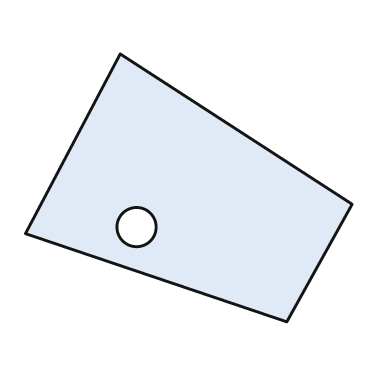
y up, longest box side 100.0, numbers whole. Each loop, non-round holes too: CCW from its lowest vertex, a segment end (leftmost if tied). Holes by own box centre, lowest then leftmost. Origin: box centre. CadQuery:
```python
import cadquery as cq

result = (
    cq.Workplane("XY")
    .moveTo(30.0, -41.0)
    .lineTo(50.0, -5.0)
    .lineTo(-21.0, 41.0)
    .lineTo(-50.0, -14.0)
    .close()
    .moveTo(-16.0, -12.0)
    .circle(6.0)
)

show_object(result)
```